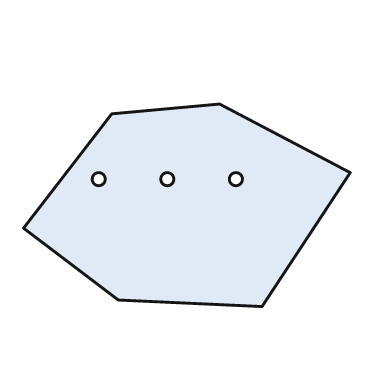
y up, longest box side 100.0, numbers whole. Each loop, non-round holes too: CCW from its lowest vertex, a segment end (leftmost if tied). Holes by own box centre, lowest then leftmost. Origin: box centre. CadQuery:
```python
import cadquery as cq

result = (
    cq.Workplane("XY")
    .moveTo(23.0, -31.0)
    .lineTo(50.0, 10.0)
    .lineTo(10.0, 31.0)
    .lineTo(-23.0, 28.0)
    .lineTo(-50.0, -7.0)
    .lineTo(-21.0, -29.0)
    .close()
    .moveTo(-27.0, 8.0)
    .circle(2.0)
    .moveTo(-6.0, 8.0)
    .circle(2.0)
    .moveTo(15.0, 8.0)
    .circle(2.0)
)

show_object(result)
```